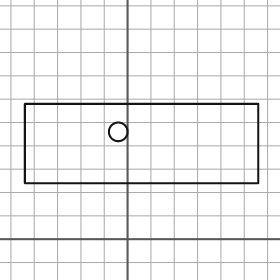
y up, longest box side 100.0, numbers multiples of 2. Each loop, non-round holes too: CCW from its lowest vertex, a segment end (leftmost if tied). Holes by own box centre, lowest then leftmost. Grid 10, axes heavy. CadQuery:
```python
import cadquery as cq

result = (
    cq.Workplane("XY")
    .moveTo(-44.0, 24.0)
    .lineTo(56.0, 24.0)
    .lineTo(56.0, 58.0)
    .lineTo(-44.0, 58.0)
    .close()
    .moveTo(-4.0, 46.0)
    .circle(4.0)
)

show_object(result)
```